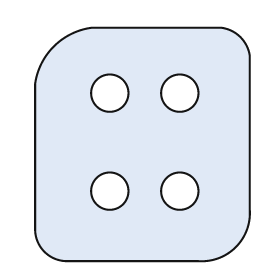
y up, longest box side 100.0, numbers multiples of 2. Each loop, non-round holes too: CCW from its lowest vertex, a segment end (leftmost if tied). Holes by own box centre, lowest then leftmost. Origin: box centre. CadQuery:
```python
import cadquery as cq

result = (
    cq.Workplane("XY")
    .moveTo(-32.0, -50.0)
    .lineTo(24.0, -50.0)
    .threePointArc((40.0, -44.0), (46.0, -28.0))
    .lineTo(46.0, 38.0)
    .threePointArc((42.0, 46.0), (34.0, 50.0))
    .lineTo(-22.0, 50.0)
    .threePointArc((-38.0, 42.0), (-46.0, 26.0))
    .lineTo(-46.0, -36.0)
    .threePointArc((-42.0, -46.0), (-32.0, -50.0))
    .close()
    .moveTo(-14.0, -20.0)
    .circle(8.0)
    .moveTo(16.0, -20.0)
    .circle(8.0)
    .moveTo(-14.0, 22.0)
    .circle(8.0)
    .moveTo(16.0, 22.0)
    .circle(8.0)
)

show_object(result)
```